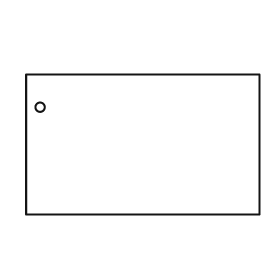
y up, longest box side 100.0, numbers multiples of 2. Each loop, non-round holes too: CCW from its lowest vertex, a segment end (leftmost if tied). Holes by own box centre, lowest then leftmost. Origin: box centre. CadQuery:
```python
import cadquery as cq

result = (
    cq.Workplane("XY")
    .moveTo(-50.0, -30.0)
    .lineTo(50.0, -30.0)
    .lineTo(50.0, 30.0)
    .lineTo(-50.0, 30.0)
    .close()
    .moveTo(-44.0, 16.0)
    .circle(2.0)
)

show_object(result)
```